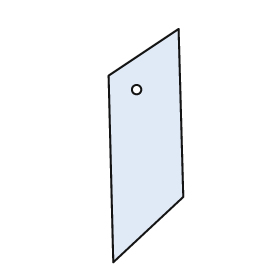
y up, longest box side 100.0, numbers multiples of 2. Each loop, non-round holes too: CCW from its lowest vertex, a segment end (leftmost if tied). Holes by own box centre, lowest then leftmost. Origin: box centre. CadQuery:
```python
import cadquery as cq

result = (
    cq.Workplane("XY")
    .moveTo(-14.0, -50.0)
    .lineTo(16.0, -22.0)
    .lineTo(14.0, 50.0)
    .lineTo(-16.0, 30.0)
    .close()
    .moveTo(-4.0, 24.0)
    .circle(2.0)
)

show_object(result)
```